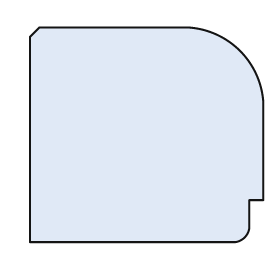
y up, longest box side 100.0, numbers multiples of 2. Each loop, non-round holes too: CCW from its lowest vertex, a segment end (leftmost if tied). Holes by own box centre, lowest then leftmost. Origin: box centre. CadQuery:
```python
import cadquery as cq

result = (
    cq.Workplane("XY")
    .moveTo(-50.0, -46.0)
    .lineTo(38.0, -46.0)
    .threePointArc((42.0, -44.0), (44.0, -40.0))
    .lineTo(44.0, -28.0)
    .lineTo(50.0, -28.0)
    .lineTo(50.0, 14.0)
    .threePointArc((40.0, 36.0), (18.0, 46.0))
    .lineTo(-46.0, 46.0)
    .lineTo(-50.0, 42.0)
    .close()
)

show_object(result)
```